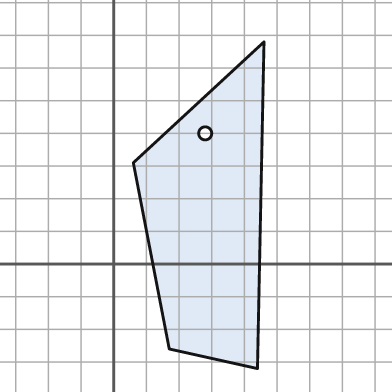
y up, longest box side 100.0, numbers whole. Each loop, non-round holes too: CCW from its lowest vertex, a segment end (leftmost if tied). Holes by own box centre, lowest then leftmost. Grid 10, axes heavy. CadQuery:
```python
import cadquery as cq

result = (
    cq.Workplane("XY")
    .moveTo(44.0, -32.0)
    .lineTo(46.0, 68.0)
    .lineTo(6.0, 31.0)
    .lineTo(17.0, -26.0)
    .close()
    .moveTo(28.0, 40.0)
    .circle(2.0)
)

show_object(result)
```